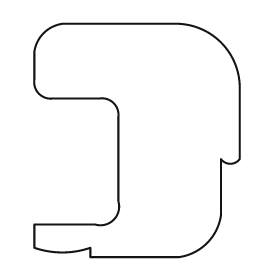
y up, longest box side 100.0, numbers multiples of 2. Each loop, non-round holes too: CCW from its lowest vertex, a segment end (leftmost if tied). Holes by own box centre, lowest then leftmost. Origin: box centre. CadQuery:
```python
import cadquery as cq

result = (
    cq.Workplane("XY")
    .moveTo(-20.0, -50.0)
    .lineTo(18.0, -50.0)
    .threePointArc((30.0, -44.0), (36.0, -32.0))
    .lineTo(36.0, -8.0)
    .threePointArc((40.0, -10.0), (44.0, -8.0))
    .lineTo(44.0, 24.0)
    .threePointArc((36.0, 42.0), (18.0, 50.0))
    .lineTo(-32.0, 50.0)
    .threePointArc((-40.0, 46.0), (-44.0, 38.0))
    .lineTo(-44.0, 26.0)
    .threePointArc((-42.0, 20.0), (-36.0, 18.0))
    .lineTo(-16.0, 18.0)
    .threePointArc((-10.0, 16.0), (-8.0, 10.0))
    .lineTo(-8.0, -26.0)
    .threePointArc((-10.0, -34.0), (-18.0, -36.0))
    .lineTo(-44.0, -36.0)
    .lineTo(-44.0, -46.0)
    .threePointArc((-32.0, -48.0), (-20.0, -46.0))
    .close()
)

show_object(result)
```